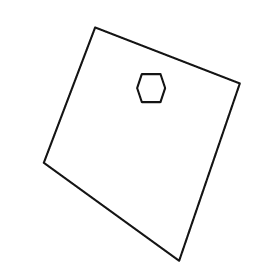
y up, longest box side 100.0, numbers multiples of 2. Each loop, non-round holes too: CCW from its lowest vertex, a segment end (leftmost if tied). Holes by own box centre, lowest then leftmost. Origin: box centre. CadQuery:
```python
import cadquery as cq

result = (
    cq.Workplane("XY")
    .moveTo(16.0, -50.0)
    .lineTo(42.0, 26.0)
    .lineTo(-20.0, 50.0)
    .lineTo(-42.0, -8.0)
    .close()
    .moveTo(0.0, 18.0)
    .lineTo(8.0, 18.0)
    .lineTo(10.0, 24.0)
    .lineTo(8.0, 30.0)
    .lineTo(0.0, 30.0)
    .lineTo(-2.0, 24.0)
    .close()
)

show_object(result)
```